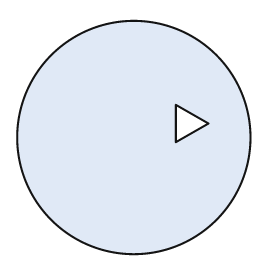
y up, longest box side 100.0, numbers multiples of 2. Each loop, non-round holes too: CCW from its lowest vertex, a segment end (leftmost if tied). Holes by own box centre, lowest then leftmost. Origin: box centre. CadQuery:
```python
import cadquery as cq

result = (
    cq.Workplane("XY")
    .moveTo(0.0, 0.0)
    .circle(50.0)
    .moveTo(18.0, -2.0)
    .lineTo(32.0, 6.0)
    .lineTo(18.0, 14.0)
    .close()
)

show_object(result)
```